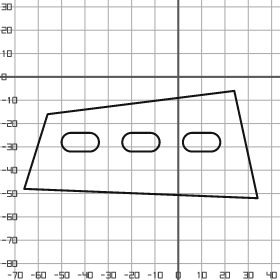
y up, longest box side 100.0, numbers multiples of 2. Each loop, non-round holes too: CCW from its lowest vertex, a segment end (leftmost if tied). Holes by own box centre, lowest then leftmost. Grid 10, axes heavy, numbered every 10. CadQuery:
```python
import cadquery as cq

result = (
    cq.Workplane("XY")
    .moveTo(34.0, -52.0)
    .lineTo(24.0, -6.0)
    .lineTo(-56.0, -16.0)
    .lineTo(-66.0, -48.0)
    .close()
    .moveTo(-46.0, -32.0)
    .lineTo(-38.0, -32.0)
    .threePointArc((-34.0, -28.0), (-38.0, -24.0))
    .lineTo(-46.0, -24.0)
    .threePointArc((-50.0, -28.0), (-46.0, -32.0))
    .close()
    .moveTo(-20.0, -32.0)
    .lineTo(-12.0, -32.0)
    .threePointArc((-8.0, -28.0), (-12.0, -24.0))
    .lineTo(-20.0, -24.0)
    .threePointArc((-24.0, -28.0), (-20.0, -32.0))
    .close()
    .moveTo(6.0, -32.0)
    .lineTo(14.0, -32.0)
    .threePointArc((18.0, -28.0), (14.0, -24.0))
    .lineTo(6.0, -24.0)
    .threePointArc((2.0, -28.0), (6.0, -32.0))
    .close()
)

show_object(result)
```